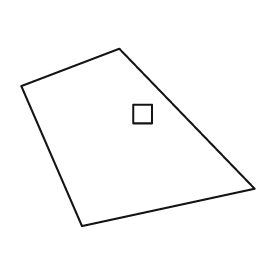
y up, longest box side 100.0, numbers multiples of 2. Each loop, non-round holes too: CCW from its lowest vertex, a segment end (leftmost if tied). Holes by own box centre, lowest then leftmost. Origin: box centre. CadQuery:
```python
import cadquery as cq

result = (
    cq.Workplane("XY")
    .moveTo(-24.0, -38.0)
    .lineTo(50.0, -22.0)
    .lineTo(-8.0, 38.0)
    .lineTo(-50.0, 22.0)
    .close()
    .moveTo(-2.0, 6.0)
    .lineTo(6.0, 6.0)
    .lineTo(6.0, 14.0)
    .lineTo(-2.0, 14.0)
    .close()
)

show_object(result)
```